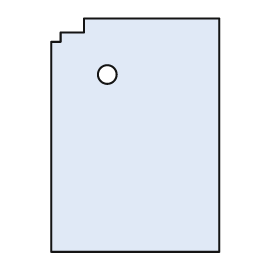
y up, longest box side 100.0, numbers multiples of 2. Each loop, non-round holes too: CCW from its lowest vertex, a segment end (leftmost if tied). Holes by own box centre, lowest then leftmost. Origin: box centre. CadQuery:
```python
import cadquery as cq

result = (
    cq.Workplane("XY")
    .moveTo(-36.0, -50.0)
    .lineTo(36.0, -50.0)
    .lineTo(36.0, 50.0)
    .lineTo(-22.0, 50.0)
    .lineTo(-22.0, 44.0)
    .lineTo(-32.0, 44.0)
    .lineTo(-32.0, 40.0)
    .lineTo(-36.0, 40.0)
    .close()
    .moveTo(-12.0, 26.0)
    .circle(4.0)
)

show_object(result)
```